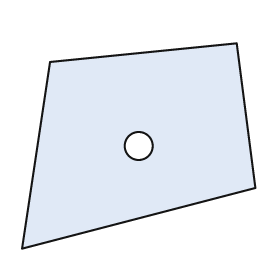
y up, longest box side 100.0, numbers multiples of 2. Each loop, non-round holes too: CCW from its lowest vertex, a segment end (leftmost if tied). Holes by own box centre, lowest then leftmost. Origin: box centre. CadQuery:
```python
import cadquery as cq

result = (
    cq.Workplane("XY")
    .moveTo(-50.0, -44.0)
    .lineTo(50.0, -18.0)
    .lineTo(42.0, 44.0)
    .lineTo(-38.0, 36.0)
    .close()
    .moveTo(0.0, 0.0)
    .circle(6.0)
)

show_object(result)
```